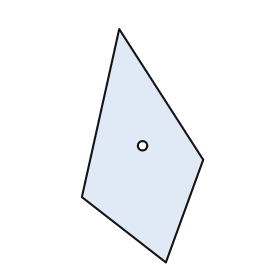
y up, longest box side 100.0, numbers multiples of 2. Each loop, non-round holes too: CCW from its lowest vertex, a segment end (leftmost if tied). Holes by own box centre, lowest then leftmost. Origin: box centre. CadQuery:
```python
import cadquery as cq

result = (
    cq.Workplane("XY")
    .moveTo(10.0, -50.0)
    .lineTo(26.0, -6.0)
    .lineTo(-10.0, 50.0)
    .lineTo(-26.0, -22.0)
    .close()
    .moveTo(0.0, 0.0)
    .circle(2.0)
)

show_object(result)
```